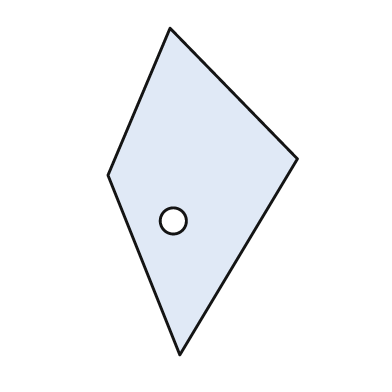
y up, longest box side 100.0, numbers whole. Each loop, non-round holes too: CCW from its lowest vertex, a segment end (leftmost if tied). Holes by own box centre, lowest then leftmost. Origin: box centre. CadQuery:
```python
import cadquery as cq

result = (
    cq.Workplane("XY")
    .moveTo(-7.0, -50.0)
    .lineTo(29.0, 10.0)
    .lineTo(-10.0, 50.0)
    .lineTo(-29.0, 5.0)
    .close()
    .moveTo(-9.0, -9.0)
    .circle(4.0)
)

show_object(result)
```